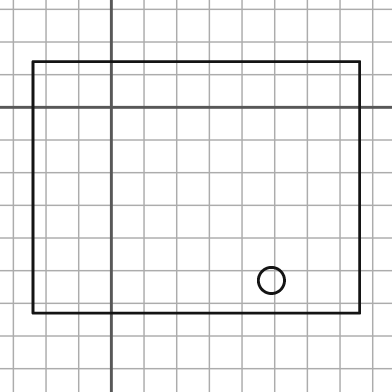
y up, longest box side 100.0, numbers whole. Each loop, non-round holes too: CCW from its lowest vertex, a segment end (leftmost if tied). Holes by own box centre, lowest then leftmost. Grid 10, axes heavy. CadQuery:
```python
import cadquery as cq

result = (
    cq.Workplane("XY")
    .moveTo(-24.0, -63.0)
    .lineTo(76.0, -63.0)
    .lineTo(76.0, 14.0)
    .lineTo(-24.0, 14.0)
    .close()
    .moveTo(49.0, -53.0)
    .circle(4.0)
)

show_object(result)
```